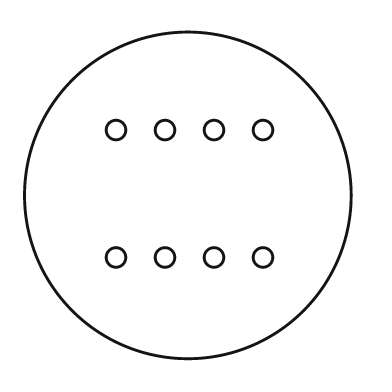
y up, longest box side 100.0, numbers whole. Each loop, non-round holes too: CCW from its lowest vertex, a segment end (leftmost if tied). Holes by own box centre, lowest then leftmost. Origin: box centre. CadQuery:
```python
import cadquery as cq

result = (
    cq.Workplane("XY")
    .moveTo(0.0, 0.0)
    .circle(50.0)
    .moveTo(-22.0, -19.0)
    .circle(3.0)
    .moveTo(-7.0, -19.0)
    .circle(3.0)
    .moveTo(8.0, -19.0)
    .circle(3.0)
    .moveTo(23.0, -19.0)
    .circle(3.0)
    .moveTo(-22.0, 20.0)
    .circle(3.0)
    .moveTo(-7.0, 20.0)
    .circle(3.0)
    .moveTo(8.0, 20.0)
    .circle(3.0)
    .moveTo(23.0, 20.0)
    .circle(3.0)
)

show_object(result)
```